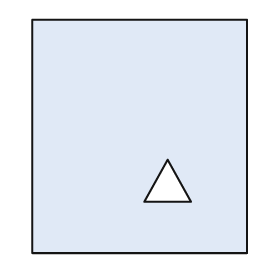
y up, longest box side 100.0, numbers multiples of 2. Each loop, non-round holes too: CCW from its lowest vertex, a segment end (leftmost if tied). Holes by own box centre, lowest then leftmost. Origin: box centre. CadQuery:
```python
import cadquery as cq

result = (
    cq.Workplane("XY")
    .moveTo(-46.0, -50.0)
    .lineTo(46.0, -50.0)
    .lineTo(46.0, 50.0)
    .lineTo(-46.0, 50.0)
    .close()
    .moveTo(2.0, -28.0)
    .lineTo(22.0, -28.0)
    .lineTo(12.0, -10.0)
    .close()
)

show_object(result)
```